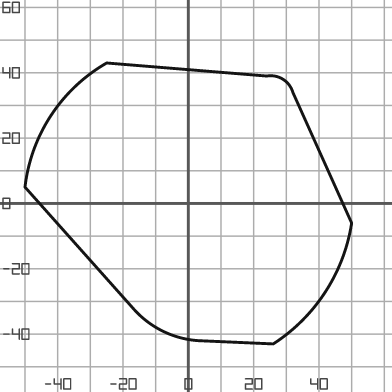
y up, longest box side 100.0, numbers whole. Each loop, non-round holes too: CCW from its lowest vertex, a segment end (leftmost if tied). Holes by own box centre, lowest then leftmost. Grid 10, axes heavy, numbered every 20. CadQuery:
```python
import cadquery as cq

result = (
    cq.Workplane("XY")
    .moveTo(26.0, -43.0)
    .threePointArc((42.0, -27.0), (50.0, -6.0))
    .lineTo(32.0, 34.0)
    .threePointArc((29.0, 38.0), (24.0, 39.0))
    .lineTo(-25.0, 43.0)
    .threePointArc((-42.0, 27.0), (-50.0, 5.0))
    .lineTo(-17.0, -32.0)
    .threePointArc((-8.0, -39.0), (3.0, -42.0))
    .close()
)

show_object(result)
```